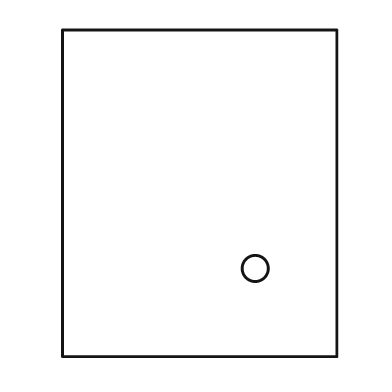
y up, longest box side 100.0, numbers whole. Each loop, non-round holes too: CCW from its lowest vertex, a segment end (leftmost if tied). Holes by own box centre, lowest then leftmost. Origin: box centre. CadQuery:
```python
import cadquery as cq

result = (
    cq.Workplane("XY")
    .moveTo(-42.0, -50.0)
    .lineTo(42.0, -50.0)
    .lineTo(42.0, 50.0)
    .lineTo(-42.0, 50.0)
    .close()
    .moveTo(17.0, -23.0)
    .circle(4.0)
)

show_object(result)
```